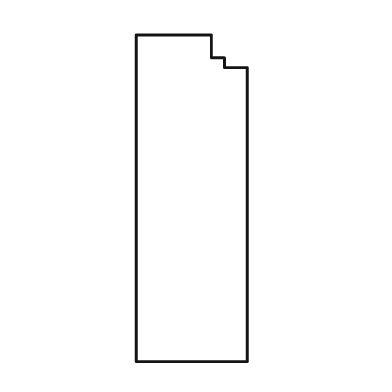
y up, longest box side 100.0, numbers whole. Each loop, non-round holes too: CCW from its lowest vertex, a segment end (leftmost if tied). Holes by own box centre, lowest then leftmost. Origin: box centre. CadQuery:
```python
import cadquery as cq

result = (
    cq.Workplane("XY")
    .moveTo(-17.0, -50.0)
    .lineTo(17.0, -50.0)
    .lineTo(17.0, 40.0)
    .lineTo(10.0, 40.0)
    .lineTo(10.0, 43.0)
    .lineTo(6.0, 43.0)
    .lineTo(6.0, 50.0)
    .lineTo(-17.0, 50.0)
    .close()
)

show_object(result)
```